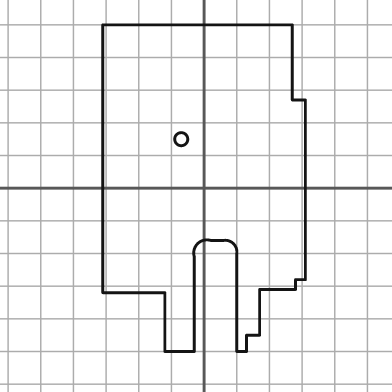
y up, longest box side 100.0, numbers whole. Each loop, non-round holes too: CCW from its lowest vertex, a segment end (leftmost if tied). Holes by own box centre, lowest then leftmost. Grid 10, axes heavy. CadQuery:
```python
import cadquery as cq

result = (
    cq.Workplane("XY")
    .moveTo(-12.0, -50.0)
    .lineTo(-3.0, -50.0)
    .lineTo(-3.0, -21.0)
    .threePointArc((-2.0, -17.0), (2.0, -16.0))
    .lineTo(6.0, -16.0)
    .threePointArc((9.0, -17.0), (10.0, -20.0))
    .lineTo(10.0, -50.0)
    .lineTo(13.0, -50.0)
    .lineTo(13.0, -45.0)
    .lineTo(17.0, -45.0)
    .lineTo(17.0, -31.0)
    .lineTo(28.0, -31.0)
    .lineTo(28.0, -28.0)
    .lineTo(31.0, -28.0)
    .lineTo(31.0, 27.0)
    .lineTo(27.0, 27.0)
    .lineTo(27.0, 50.0)
    .lineTo(-31.0, 50.0)
    .lineTo(-31.0, -32.0)
    .lineTo(-12.0, -32.0)
    .close()
    .moveTo(-7.0, 15.0)
    .circle(2.0)
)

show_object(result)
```